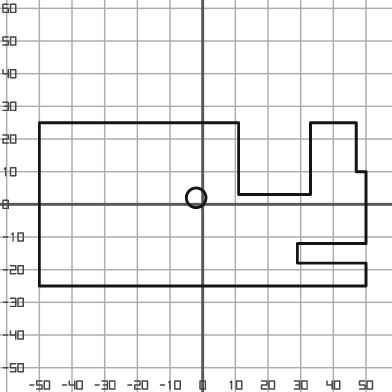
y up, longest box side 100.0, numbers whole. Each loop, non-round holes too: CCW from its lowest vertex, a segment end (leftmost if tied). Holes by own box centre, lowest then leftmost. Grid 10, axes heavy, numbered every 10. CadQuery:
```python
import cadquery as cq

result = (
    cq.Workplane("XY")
    .moveTo(-50.0, -25.0)
    .lineTo(50.0, -25.0)
    .lineTo(50.0, -18.0)
    .lineTo(29.0, -18.0)
    .lineTo(29.0, -12.0)
    .lineTo(50.0, -12.0)
    .lineTo(50.0, 10.0)
    .lineTo(47.0, 10.0)
    .lineTo(47.0, 25.0)
    .lineTo(33.0, 25.0)
    .lineTo(33.0, 3.0)
    .lineTo(11.0, 3.0)
    .lineTo(11.0, 25.0)
    .lineTo(-50.0, 25.0)
    .close()
    .moveTo(-2.0, 2.0)
    .circle(3.0)
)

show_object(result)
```